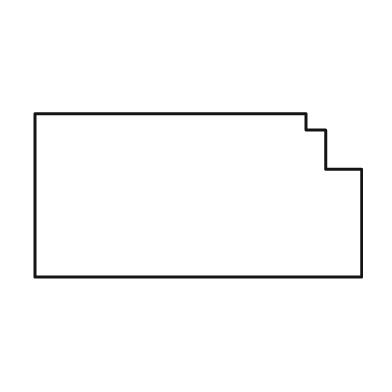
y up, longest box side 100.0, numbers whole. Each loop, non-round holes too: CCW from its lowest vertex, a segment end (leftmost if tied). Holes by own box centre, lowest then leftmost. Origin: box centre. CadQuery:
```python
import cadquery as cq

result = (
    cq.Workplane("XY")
    .moveTo(-50.0, -25.0)
    .lineTo(50.0, -25.0)
    .lineTo(50.0, 8.0)
    .lineTo(39.0, 8.0)
    .lineTo(39.0, 20.0)
    .lineTo(33.0, 20.0)
    .lineTo(33.0, 25.0)
    .lineTo(-50.0, 25.0)
    .close()
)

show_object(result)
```